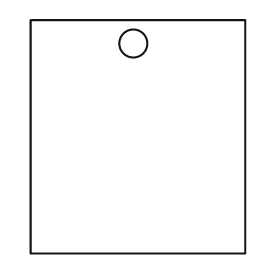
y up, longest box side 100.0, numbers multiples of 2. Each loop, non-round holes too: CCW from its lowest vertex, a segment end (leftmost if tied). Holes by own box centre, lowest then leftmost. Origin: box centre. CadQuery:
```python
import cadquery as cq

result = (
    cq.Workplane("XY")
    .moveTo(-46.0, -50.0)
    .lineTo(46.0, -50.0)
    .lineTo(46.0, 50.0)
    .lineTo(-46.0, 50.0)
    .close()
    .moveTo(-2.0, 40.0)
    .circle(6.0)
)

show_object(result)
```